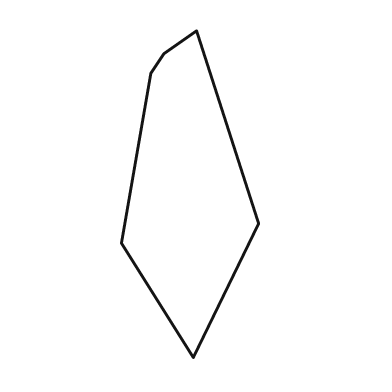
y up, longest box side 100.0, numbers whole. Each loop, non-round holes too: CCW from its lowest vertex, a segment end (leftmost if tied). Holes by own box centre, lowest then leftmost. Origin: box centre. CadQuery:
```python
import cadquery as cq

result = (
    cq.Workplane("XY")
    .moveTo(1.0, -50.0)
    .lineTo(21.0, -9.0)
    .lineTo(2.0, 50.0)
    .lineTo(-8.0, 43.0)
    .lineTo(-12.0, 37.0)
    .lineTo(-21.0, -15.0)
    .close()
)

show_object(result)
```